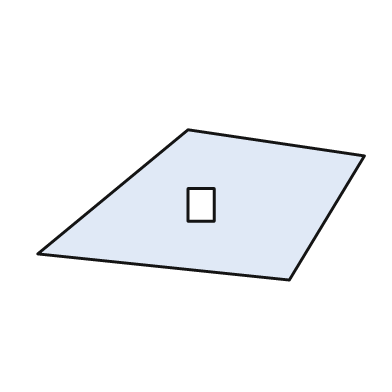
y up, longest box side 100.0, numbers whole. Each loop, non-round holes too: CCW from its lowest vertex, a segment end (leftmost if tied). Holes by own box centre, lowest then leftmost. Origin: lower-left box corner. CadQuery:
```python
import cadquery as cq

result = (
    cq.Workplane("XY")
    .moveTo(77.0, 0.0)
    .lineTo(100.0, 38.0)
    .lineTo(46.0, 46.0)
    .lineTo(0.0, 8.0)
    .close()
    .moveTo(46.0, 18.0)
    .lineTo(54.0, 18.0)
    .lineTo(54.0, 28.0)
    .lineTo(46.0, 28.0)
    .close()
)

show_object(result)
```